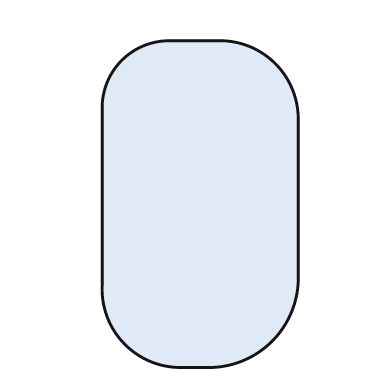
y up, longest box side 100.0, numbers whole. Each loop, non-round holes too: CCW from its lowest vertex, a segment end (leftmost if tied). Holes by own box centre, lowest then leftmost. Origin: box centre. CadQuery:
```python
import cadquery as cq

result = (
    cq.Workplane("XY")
    .moveTo(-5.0, -50.0)
    .lineTo(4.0, -50.0)
    .threePointArc((22.0, -42.0), (30.0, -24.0))
    .lineTo(30.0, 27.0)
    .threePointArc((23.0, 43.0), (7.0, 50.0))
    .lineTo(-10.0, 50.0)
    .threePointArc((-24.0, 44.0), (-30.0, 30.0))
    .lineTo(-30.0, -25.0)
    .threePointArc((-23.0, -43.0), (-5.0, -50.0))
    .close()
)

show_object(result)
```